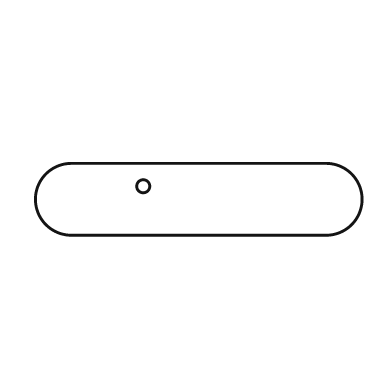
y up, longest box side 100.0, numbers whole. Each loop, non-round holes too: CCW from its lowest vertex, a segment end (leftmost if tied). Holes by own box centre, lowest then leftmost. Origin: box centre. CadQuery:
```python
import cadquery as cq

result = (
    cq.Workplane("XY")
    .moveTo(-39.0, -11.0)
    .lineTo(39.0, -11.0)
    .threePointArc((50.0, 0.0), (39.0, 11.0))
    .lineTo(-39.0, 11.0)
    .threePointArc((-50.0, 0.0), (-39.0, -11.0))
    .close()
    .moveTo(-17.0, 4.0)
    .circle(2.0)
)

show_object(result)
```